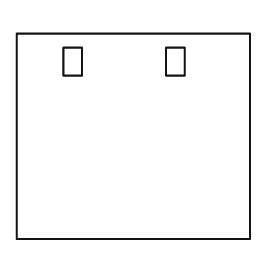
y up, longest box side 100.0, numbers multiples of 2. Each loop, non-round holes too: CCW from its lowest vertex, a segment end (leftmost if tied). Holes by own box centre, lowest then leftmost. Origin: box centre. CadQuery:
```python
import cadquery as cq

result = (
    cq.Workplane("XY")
    .moveTo(-50.0, -44.0)
    .lineTo(50.0, -44.0)
    .lineTo(50.0, 44.0)
    .lineTo(-50.0, 44.0)
    .close()
    .moveTo(-30.0, 26.0)
    .lineTo(-22.0, 26.0)
    .lineTo(-22.0, 38.0)
    .lineTo(-30.0, 38.0)
    .close()
    .moveTo(14.0, 26.0)
    .lineTo(22.0, 26.0)
    .lineTo(22.0, 38.0)
    .lineTo(14.0, 38.0)
    .close()
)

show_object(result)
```